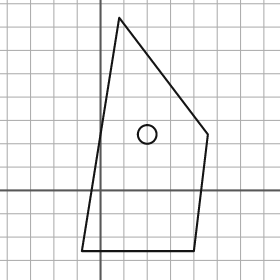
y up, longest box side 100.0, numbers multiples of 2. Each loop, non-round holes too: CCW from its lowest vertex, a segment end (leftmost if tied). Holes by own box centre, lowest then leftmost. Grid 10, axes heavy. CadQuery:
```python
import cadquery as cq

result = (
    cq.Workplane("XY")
    .moveTo(-8.0, -26.0)
    .lineTo(40.0, -26.0)
    .lineTo(46.0, 24.0)
    .lineTo(8.0, 74.0)
    .close()
    .moveTo(20.0, 24.0)
    .circle(4.0)
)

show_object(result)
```